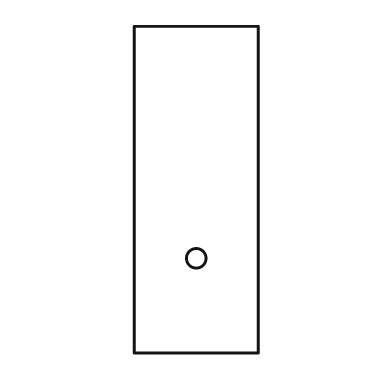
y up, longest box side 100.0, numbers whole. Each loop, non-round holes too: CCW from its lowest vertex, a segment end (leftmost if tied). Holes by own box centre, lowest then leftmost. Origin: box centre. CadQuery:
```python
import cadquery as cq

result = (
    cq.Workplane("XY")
    .moveTo(-19.0, -50.0)
    .lineTo(19.0, -50.0)
    .lineTo(19.0, 50.0)
    .lineTo(-19.0, 50.0)
    .close()
    .moveTo(0.0, -21.0)
    .circle(3.0)
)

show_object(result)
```